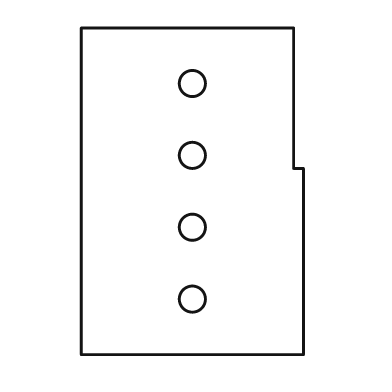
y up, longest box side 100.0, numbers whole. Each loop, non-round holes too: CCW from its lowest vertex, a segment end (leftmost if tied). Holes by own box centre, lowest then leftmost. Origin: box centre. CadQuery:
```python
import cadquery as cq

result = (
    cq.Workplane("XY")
    .moveTo(-34.0, -50.0)
    .lineTo(34.0, -50.0)
    .lineTo(34.0, 7.0)
    .lineTo(31.0, 7.0)
    .lineTo(31.0, 50.0)
    .lineTo(-34.0, 50.0)
    .close()
    .moveTo(0.0, -33.0)
    .circle(4.0)
    .moveTo(0.0, -11.0)
    .circle(4.0)
    .moveTo(0.0, 11.0)
    .circle(4.0)
    .moveTo(0.0, 33.0)
    .circle(4.0)
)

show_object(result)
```